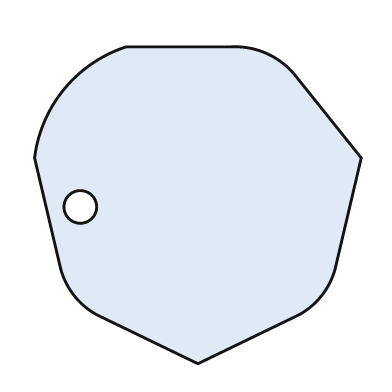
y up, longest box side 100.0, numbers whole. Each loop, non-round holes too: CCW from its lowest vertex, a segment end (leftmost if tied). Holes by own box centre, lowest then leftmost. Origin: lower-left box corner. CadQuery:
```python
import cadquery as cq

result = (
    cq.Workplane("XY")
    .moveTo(50.0, 0.0)
    .lineTo(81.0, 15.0)
    .threePointArc((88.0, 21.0), (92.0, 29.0))
    .lineTo(100.0, 63.0)
    .lineTo(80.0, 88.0)
    .threePointArc((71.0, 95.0), (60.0, 97.0))
    .lineTo(28.0, 97.0)
    .threePointArc((9.0, 84.0), (0.0, 63.0))
    .lineTo(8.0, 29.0)
    .threePointArc((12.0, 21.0), (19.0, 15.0))
    .close()
    .moveTo(14.0, 48.0)
    .circle(5.0)
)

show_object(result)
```